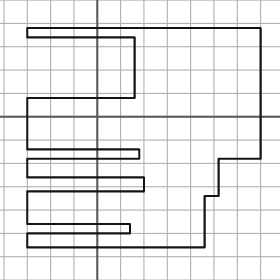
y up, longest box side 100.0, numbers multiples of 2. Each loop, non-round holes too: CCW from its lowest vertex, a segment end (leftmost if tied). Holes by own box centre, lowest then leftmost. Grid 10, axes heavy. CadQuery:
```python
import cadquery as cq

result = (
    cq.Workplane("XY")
    .moveTo(-30.0, -56.0)
    .lineTo(46.0, -56.0)
    .lineTo(46.0, -34.0)
    .lineTo(52.0, -34.0)
    .lineTo(52.0, -18.0)
    .lineTo(70.0, -18.0)
    .lineTo(70.0, 38.0)
    .lineTo(-30.0, 38.0)
    .lineTo(-30.0, 34.0)
    .lineTo(16.0, 34.0)
    .lineTo(16.0, 8.0)
    .lineTo(-30.0, 8.0)
    .lineTo(-30.0, -14.0)
    .lineTo(18.0, -14.0)
    .lineTo(18.0, -18.0)
    .lineTo(-30.0, -18.0)
    .lineTo(-30.0, -26.0)
    .lineTo(20.0, -26.0)
    .lineTo(20.0, -32.0)
    .lineTo(-30.0, -32.0)
    .lineTo(-30.0, -46.0)
    .lineTo(14.0, -46.0)
    .lineTo(14.0, -50.0)
    .lineTo(-30.0, -50.0)
    .close()
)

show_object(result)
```